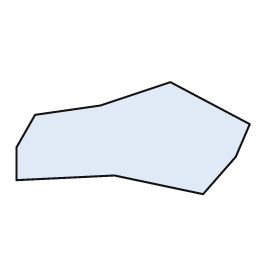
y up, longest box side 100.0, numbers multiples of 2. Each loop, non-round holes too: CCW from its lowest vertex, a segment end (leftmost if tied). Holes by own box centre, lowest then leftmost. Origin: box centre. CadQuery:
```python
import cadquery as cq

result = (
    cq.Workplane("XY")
    .moveTo(30.0, -24.0)
    .lineTo(44.0, -8.0)
    .lineTo(50.0, 6.0)
    .lineTo(16.0, 24.0)
    .lineTo(-14.0, 14.0)
    .lineTo(-42.0, 10.0)
    .lineTo(-50.0, -4.0)
    .lineTo(-50.0, -18.0)
    .lineTo(-8.0, -16.0)
    .close()
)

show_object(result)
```